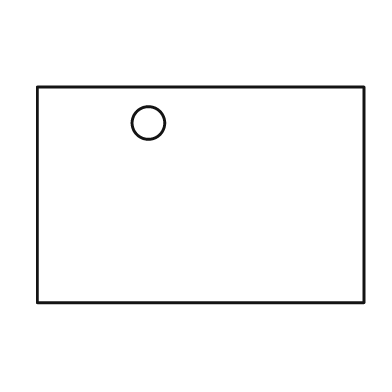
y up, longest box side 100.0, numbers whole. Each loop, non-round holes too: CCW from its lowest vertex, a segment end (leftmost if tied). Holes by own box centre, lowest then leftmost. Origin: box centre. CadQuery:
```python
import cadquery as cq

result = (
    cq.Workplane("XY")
    .moveTo(-50.0, -33.0)
    .lineTo(50.0, -33.0)
    .lineTo(50.0, 33.0)
    .lineTo(-50.0, 33.0)
    .close()
    .moveTo(-16.0, 22.0)
    .circle(5.0)
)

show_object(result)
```